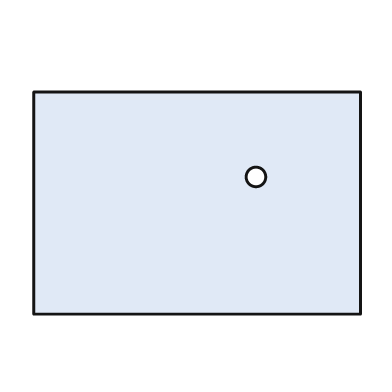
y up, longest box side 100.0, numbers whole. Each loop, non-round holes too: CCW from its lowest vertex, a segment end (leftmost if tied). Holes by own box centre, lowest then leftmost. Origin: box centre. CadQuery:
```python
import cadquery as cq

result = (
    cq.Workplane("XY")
    .moveTo(-50.0, -34.0)
    .lineTo(50.0, -34.0)
    .lineTo(50.0, 34.0)
    .lineTo(-50.0, 34.0)
    .close()
    .moveTo(18.0, 8.0)
    .circle(3.0)
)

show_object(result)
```